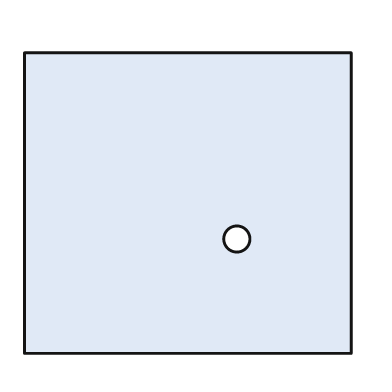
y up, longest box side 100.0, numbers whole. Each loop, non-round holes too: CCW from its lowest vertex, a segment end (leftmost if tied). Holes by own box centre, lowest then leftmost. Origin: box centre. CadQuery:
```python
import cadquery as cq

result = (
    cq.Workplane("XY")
    .moveTo(-50.0, -46.0)
    .lineTo(50.0, -46.0)
    .lineTo(50.0, 46.0)
    .lineTo(-50.0, 46.0)
    .close()
    .moveTo(15.0, -11.0)
    .circle(4.0)
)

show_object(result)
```